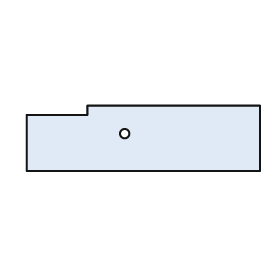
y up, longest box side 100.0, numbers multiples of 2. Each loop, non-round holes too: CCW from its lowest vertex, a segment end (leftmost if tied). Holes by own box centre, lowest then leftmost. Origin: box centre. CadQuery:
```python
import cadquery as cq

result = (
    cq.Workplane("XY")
    .moveTo(-50.0, -14.0)
    .lineTo(50.0, -14.0)
    .lineTo(50.0, 14.0)
    .lineTo(-24.0, 14.0)
    .lineTo(-24.0, 10.0)
    .lineTo(-50.0, 10.0)
    .close()
    .moveTo(-8.0, 2.0)
    .circle(2.0)
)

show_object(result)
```